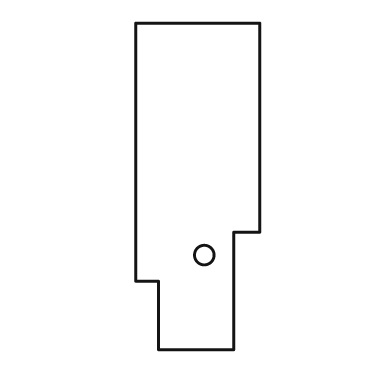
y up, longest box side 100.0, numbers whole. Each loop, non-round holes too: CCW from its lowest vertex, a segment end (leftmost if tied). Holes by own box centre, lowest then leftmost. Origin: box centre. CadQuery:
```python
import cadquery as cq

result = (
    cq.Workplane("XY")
    .moveTo(-12.0, -50.0)
    .lineTo(11.0, -50.0)
    .lineTo(11.0, -14.0)
    .lineTo(19.0, -14.0)
    .lineTo(19.0, 50.0)
    .lineTo(-19.0, 50.0)
    .lineTo(-19.0, -29.0)
    .lineTo(-12.0, -29.0)
    .close()
    .moveTo(2.0, -21.0)
    .circle(3.0)
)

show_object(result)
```